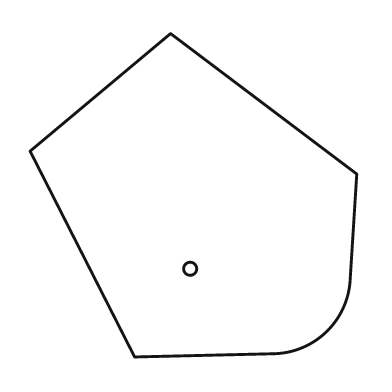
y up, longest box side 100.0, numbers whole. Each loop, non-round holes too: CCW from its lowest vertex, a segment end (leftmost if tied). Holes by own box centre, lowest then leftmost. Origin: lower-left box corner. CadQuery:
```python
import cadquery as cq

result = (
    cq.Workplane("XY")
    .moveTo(32.0, 0.0)
    .lineTo(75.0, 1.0)
    .threePointArc((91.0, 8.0), (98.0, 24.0))
    .lineTo(100.0, 56.0)
    .lineTo(43.0, 99.0)
    .lineTo(0.0, 63.0)
    .close()
    .moveTo(49.0, 27.0)
    .circle(2.0)
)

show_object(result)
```